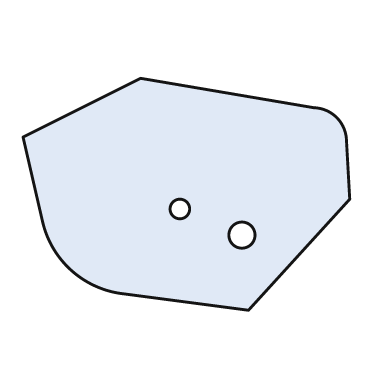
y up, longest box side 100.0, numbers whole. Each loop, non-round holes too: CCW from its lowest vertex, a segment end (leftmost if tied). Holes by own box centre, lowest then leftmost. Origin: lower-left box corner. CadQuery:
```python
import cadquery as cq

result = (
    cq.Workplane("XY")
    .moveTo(69.0, 0.0)
    .lineTo(100.0, 34.0)
    .lineTo(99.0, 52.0)
    .threePointArc((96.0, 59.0), (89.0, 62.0))
    .lineTo(36.0, 71.0)
    .lineTo(0.0, 53.0)
    .lineTo(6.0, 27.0)
    .threePointArc((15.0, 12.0), (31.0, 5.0))
    .close()
    .moveTo(67.0, 23.0)
    .circle(4.0)
    .moveTo(48.0, 31.0)
    .circle(3.0)
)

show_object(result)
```